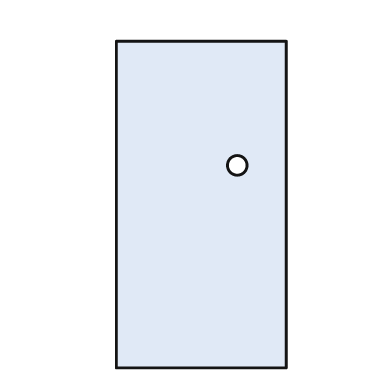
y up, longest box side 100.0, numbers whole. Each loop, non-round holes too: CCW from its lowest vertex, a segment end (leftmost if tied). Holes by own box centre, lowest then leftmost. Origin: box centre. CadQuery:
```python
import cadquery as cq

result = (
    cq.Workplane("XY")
    .moveTo(-26.0, -50.0)
    .lineTo(26.0, -50.0)
    .lineTo(26.0, 50.0)
    .lineTo(-26.0, 50.0)
    .close()
    .moveTo(11.0, 12.0)
    .circle(3.0)
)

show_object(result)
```